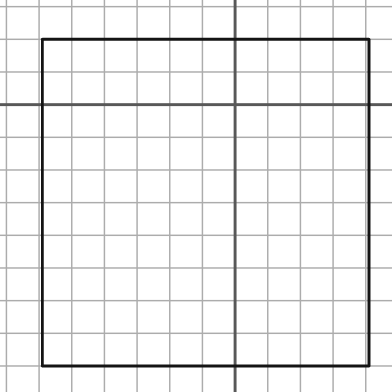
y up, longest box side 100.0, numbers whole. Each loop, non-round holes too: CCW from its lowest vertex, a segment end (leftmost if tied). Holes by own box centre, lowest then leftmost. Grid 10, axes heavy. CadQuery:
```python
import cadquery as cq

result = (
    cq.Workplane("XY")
    .moveTo(-59.0, -80.0)
    .lineTo(41.0, -80.0)
    .lineTo(41.0, 20.0)
    .lineTo(-59.0, 20.0)
    .close()
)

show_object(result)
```